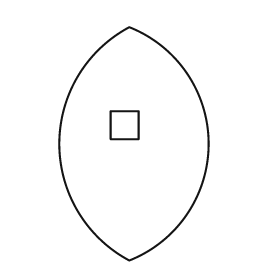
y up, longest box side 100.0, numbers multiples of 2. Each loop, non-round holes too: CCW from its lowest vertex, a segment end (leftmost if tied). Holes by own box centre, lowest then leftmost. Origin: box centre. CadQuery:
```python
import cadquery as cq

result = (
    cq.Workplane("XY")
    .moveTo(-2.0, -50.0)
    .threePointArc((32.0, 0.0), (-2.0, 50.0))
    .threePointArc((-32.0, 0.0), (-2.0, -50.0))
    .close()
    .moveTo(-10.0, 2.0)
    .lineTo(2.0, 2.0)
    .lineTo(2.0, 14.0)
    .lineTo(-10.0, 14.0)
    .close()
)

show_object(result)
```